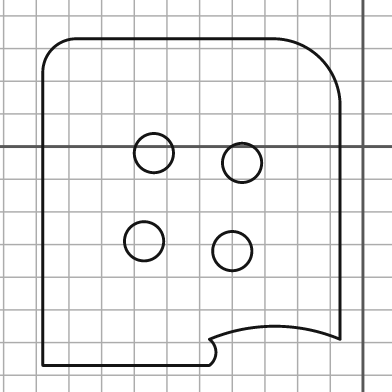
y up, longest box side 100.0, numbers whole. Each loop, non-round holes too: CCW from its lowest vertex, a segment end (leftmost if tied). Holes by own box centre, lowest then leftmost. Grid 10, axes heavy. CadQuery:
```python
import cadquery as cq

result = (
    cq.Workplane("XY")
    .moveTo(-98.0, -67.0)
    .lineTo(-47.0, -67.0)
    .threePointArc((-45.0, -63.0), (-47.0, -59.0))
    .threePointArc((-27.0, -55.0), (-7.0, -59.0))
    .lineTo(-7.0, 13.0)
    .threePointArc((-13.0, 27.0), (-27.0, 33.0))
    .lineTo(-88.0, 33.0)
    .threePointArc((-95.0, 30.0), (-98.0, 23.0))
    .close()
    .moveTo(-40.0, -32.0)
    .circle(6.0)
    .moveTo(-67.0, -29.0)
    .circle(6.0)
    .moveTo(-37.0, -5.0)
    .circle(6.0)
    .moveTo(-64.0, -2.0)
    .circle(6.0)
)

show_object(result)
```